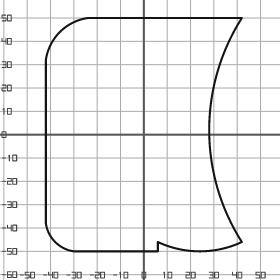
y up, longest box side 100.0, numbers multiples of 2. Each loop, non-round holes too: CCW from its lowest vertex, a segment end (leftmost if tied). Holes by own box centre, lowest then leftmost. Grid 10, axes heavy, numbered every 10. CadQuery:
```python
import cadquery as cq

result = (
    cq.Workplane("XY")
    .moveTo(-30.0, -50.0)
    .lineTo(6.0, -50.0)
    .lineTo(6.0, -46.0)
    .threePointArc((24.0, -50.0), (42.0, -46.0))
    .threePointArc((28.0, 2.0), (42.0, 50.0))
    .lineTo(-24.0, 50.0)
    .threePointArc((-36.0, 44.0), (-42.0, 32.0))
    .lineTo(-42.0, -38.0)
    .threePointArc((-38.0, -46.0), (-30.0, -50.0))
    .close()
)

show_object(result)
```